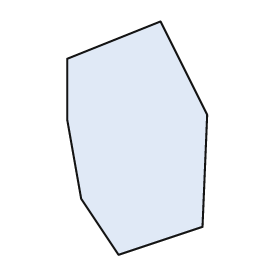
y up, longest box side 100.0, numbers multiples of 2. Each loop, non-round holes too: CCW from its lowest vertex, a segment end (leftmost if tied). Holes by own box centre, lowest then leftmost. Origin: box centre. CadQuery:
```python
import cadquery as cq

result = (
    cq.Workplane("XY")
    .moveTo(-8.0, -50.0)
    .lineTo(28.0, -38.0)
    .lineTo(30.0, 10.0)
    .lineTo(10.0, 50.0)
    .lineTo(-30.0, 34.0)
    .lineTo(-30.0, 8.0)
    .lineTo(-24.0, -26.0)
    .close()
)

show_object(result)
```